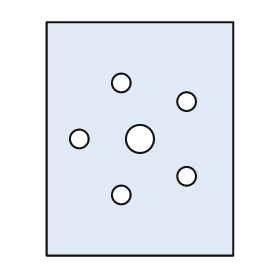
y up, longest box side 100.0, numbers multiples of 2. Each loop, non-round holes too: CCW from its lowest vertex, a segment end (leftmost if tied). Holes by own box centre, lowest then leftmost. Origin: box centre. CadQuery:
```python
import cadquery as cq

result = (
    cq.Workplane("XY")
    .moveTo(-40.0, -50.0)
    .lineTo(40.0, -50.0)
    .lineTo(40.0, 50.0)
    .lineTo(-40.0, 50.0)
    .close()
    .moveTo(-8.0, -24.0)
    .circle(4.0)
    .moveTo(20.0, -16.0)
    .circle(4.0)
    .moveTo(-26.0, 0.0)
    .circle(4.0)
    .moveTo(0.0, 0.0)
    .circle(6.0)
    .moveTo(20.0, 16.0)
    .circle(4.0)
    .moveTo(-8.0, 24.0)
    .circle(4.0)
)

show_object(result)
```